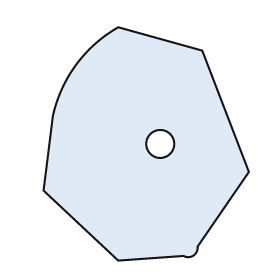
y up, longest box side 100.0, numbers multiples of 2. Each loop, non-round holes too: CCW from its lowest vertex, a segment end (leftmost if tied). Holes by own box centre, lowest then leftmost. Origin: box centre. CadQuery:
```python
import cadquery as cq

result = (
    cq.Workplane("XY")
    .moveTo(-12.0, -50.0)
    .lineTo(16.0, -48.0)
    .threePointArc((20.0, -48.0), (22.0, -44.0))
    .lineTo(44.0, -12.0)
    .lineTo(24.0, 40.0)
    .lineTo(-12.0, 50.0)
    .threePointArc((-30.0, 34.0), (-40.0, 12.0))
    .lineTo(-44.0, -20.0)
    .close()
    .moveTo(6.0, 0.0)
    .circle(6.0)
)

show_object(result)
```